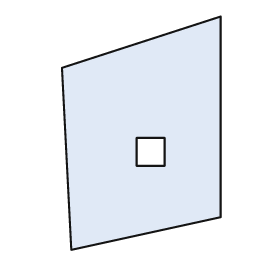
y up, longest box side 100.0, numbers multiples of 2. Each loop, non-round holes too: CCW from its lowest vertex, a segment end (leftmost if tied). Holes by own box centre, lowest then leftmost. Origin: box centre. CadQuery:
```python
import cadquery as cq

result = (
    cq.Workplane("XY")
    .moveTo(-30.0, -50.0)
    .lineTo(34.0, -36.0)
    .lineTo(34.0, 50.0)
    .lineTo(-34.0, 28.0)
    .close()
    .moveTo(-2.0, -14.0)
    .lineTo(10.0, -14.0)
    .lineTo(10.0, -2.0)
    .lineTo(-2.0, -2.0)
    .close()
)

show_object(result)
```